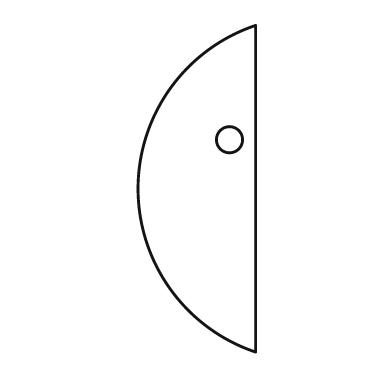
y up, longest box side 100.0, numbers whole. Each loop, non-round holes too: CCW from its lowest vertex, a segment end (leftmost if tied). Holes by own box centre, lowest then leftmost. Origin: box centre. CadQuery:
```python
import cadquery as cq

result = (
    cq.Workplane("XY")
    .moveTo(18.0, -50.0)
    .lineTo(18.0, 50.0)
    .threePointArc((-18.0, 0.0), (18.0, -50.0))
    .close()
    .moveTo(10.0, 15.0)
    .circle(4.0)
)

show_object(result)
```